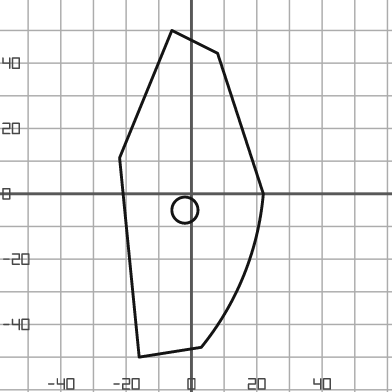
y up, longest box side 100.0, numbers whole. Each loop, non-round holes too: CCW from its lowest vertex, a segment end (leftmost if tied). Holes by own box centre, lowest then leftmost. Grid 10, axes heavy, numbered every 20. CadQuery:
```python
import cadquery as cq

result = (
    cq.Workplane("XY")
    .moveTo(-16.0, -50.0)
    .lineTo(3.0, -47.0)
    .threePointArc((16.0, -25.0), (22.0, 0.0))
    .lineTo(8.0, 43.0)
    .lineTo(-6.0, 50.0)
    .lineTo(-22.0, 11.0)
    .close()
    .moveTo(-2.0, -5.0)
    .circle(4.0)
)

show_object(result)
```